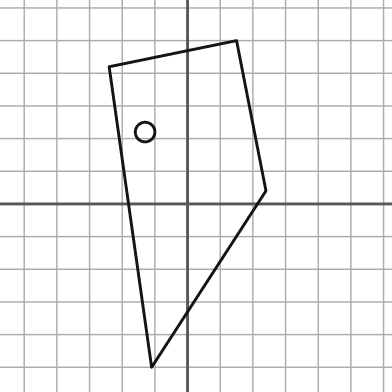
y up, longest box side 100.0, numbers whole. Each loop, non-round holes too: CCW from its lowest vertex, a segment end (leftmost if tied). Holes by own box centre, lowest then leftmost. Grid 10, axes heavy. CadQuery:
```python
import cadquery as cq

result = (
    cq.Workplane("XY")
    .moveTo(-11.0, -50.0)
    .lineTo(24.0, 4.0)
    .lineTo(15.0, 50.0)
    .lineTo(-24.0, 42.0)
    .close()
    .moveTo(-13.0, 22.0)
    .circle(3.0)
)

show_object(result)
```